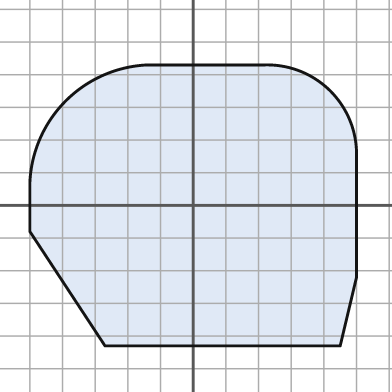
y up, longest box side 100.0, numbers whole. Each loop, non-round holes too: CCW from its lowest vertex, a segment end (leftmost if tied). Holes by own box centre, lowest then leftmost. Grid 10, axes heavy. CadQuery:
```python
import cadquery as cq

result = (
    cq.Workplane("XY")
    .moveTo(-27.0, -43.0)
    .lineTo(45.0, -43.0)
    .lineTo(50.0, -22.0)
    .lineTo(50.0, 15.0)
    .threePointArc((42.0, 35.0), (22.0, 43.0))
    .lineTo(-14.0, 43.0)
    .threePointArc((-39.0, 32.0), (-50.0, 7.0))
    .lineTo(-50.0, -8.0)
    .close()
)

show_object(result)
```